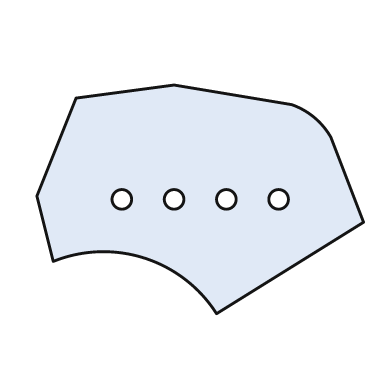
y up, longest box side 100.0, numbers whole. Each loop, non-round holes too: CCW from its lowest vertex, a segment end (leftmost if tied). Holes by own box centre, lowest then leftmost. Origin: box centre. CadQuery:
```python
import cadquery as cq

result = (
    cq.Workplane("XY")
    .moveTo(5.0, -35.0)
    .lineTo(50.0, -7.0)
    .lineTo(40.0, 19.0)
    .threePointArc((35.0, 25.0), (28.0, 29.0))
    .lineTo(-8.0, 35.0)
    .lineTo(-38.0, 31.0)
    .lineTo(-50.0, 1.0)
    .lineTo(-45.0, -19.0)
    .threePointArc((-17.0, -18.0), (5.0, -35.0))
    .close()
    .moveTo(-24.0, 0.0)
    .circle(3.0)
    .moveTo(-8.0, 0.0)
    .circle(3.0)
    .moveTo(8.0, 0.0)
    .circle(3.0)
    .moveTo(24.0, 0.0)
    .circle(3.0)
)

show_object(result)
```